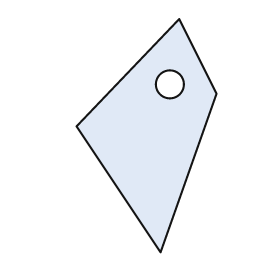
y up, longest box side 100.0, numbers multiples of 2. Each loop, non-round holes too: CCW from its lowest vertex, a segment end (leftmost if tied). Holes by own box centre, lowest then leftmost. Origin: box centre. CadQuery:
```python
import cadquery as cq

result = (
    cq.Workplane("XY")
    .moveTo(6.0, -50.0)
    .lineTo(30.0, 18.0)
    .lineTo(14.0, 50.0)
    .lineTo(-30.0, 4.0)
    .close()
    .moveTo(10.0, 22.0)
    .circle(6.0)
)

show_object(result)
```